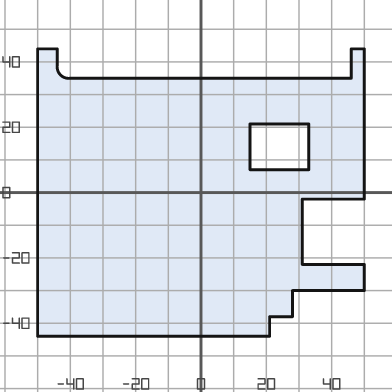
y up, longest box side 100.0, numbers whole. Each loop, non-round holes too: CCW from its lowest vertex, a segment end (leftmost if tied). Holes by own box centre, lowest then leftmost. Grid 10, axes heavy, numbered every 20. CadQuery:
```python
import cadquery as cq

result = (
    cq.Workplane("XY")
    .moveTo(-50.0, -44.0)
    .lineTo(21.0, -44.0)
    .lineTo(21.0, -38.0)
    .lineTo(28.0, -38.0)
    .lineTo(28.0, -30.0)
    .lineTo(50.0, -30.0)
    .lineTo(50.0, -22.0)
    .lineTo(31.0, -22.0)
    .lineTo(31.0, -2.0)
    .lineTo(50.0, -2.0)
    .lineTo(50.0, 44.0)
    .lineTo(46.0, 44.0)
    .lineTo(46.0, 35.0)
    .lineTo(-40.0, 35.0)
    .threePointArc((-43.0, 36.0), (-44.0, 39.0))
    .lineTo(-44.0, 44.0)
    .lineTo(-50.0, 44.0)
    .close()
    .moveTo(15.0, 7.0)
    .lineTo(33.0, 7.0)
    .lineTo(33.0, 21.0)
    .lineTo(15.0, 21.0)
    .close()
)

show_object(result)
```